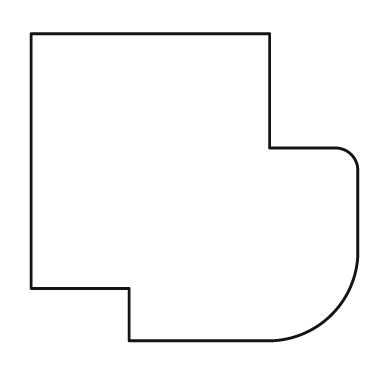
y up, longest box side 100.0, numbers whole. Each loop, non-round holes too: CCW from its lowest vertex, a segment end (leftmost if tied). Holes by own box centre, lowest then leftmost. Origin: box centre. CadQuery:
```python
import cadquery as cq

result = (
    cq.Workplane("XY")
    .moveTo(-20.0, -47.0)
    .lineTo(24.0, -47.0)
    .threePointArc((42.0, -39.0), (50.0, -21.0))
    .lineTo(50.0, 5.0)
    .threePointArc((48.0, 10.0), (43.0, 12.0))
    .lineTo(23.0, 12.0)
    .lineTo(23.0, 47.0)
    .lineTo(-50.0, 47.0)
    .lineTo(-50.0, -31.0)
    .lineTo(-20.0, -31.0)
    .close()
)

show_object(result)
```